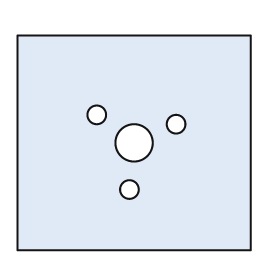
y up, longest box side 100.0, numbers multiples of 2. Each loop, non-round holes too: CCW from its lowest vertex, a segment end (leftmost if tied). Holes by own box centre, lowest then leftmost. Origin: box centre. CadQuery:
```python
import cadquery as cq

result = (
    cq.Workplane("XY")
    .moveTo(-50.0, -46.0)
    .lineTo(50.0, -46.0)
    .lineTo(50.0, 46.0)
    .lineTo(-50.0, 46.0)
    .close()
    .moveTo(-2.0, -20.0)
    .circle(4.0)
    .moveTo(0.0, 0.0)
    .circle(8.0)
    .moveTo(18.0, 8.0)
    .circle(4.0)
    .moveTo(-16.0, 12.0)
    .circle(4.0)
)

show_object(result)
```